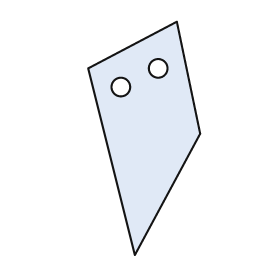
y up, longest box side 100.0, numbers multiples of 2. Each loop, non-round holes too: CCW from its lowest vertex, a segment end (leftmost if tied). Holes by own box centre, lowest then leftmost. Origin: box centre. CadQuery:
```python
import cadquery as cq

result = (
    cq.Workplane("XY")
    .moveTo(-4.0, -50.0)
    .lineTo(24.0, 2.0)
    .lineTo(14.0, 50.0)
    .lineTo(-24.0, 30.0)
    .close()
    .moveTo(-10.0, 22.0)
    .circle(4.0)
    .moveTo(6.0, 30.0)
    .circle(4.0)
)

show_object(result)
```